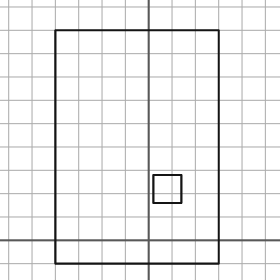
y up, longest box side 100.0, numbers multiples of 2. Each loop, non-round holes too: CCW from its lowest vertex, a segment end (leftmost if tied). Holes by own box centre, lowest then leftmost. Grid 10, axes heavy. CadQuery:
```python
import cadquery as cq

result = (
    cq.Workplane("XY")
    .moveTo(-40.0, -10.0)
    .lineTo(30.0, -10.0)
    .lineTo(30.0, 90.0)
    .lineTo(-40.0, 90.0)
    .close()
    .moveTo(2.0, 16.0)
    .lineTo(14.0, 16.0)
    .lineTo(14.0, 28.0)
    .lineTo(2.0, 28.0)
    .close()
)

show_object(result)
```